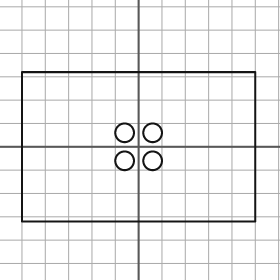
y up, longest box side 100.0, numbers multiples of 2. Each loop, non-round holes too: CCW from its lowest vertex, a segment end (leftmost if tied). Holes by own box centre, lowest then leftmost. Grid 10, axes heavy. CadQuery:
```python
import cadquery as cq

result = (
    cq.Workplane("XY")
    .moveTo(-50.0, -32.0)
    .lineTo(50.0, -32.0)
    .lineTo(50.0, 32.0)
    .lineTo(-50.0, 32.0)
    .close()
    .moveTo(-6.0, -6.0)
    .circle(4.0)
    .moveTo(6.0, -6.0)
    .circle(4.0)
    .moveTo(-6.0, 6.0)
    .circle(4.0)
    .moveTo(6.0, 6.0)
    .circle(4.0)
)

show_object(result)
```